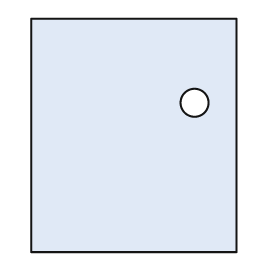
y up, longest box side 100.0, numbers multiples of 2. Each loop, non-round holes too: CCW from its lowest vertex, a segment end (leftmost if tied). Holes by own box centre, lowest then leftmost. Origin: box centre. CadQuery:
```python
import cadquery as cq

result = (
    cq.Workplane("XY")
    .moveTo(-44.0, -50.0)
    .lineTo(44.0, -50.0)
    .lineTo(44.0, 50.0)
    .lineTo(-44.0, 50.0)
    .close()
    .moveTo(26.0, 14.0)
    .circle(6.0)
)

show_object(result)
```